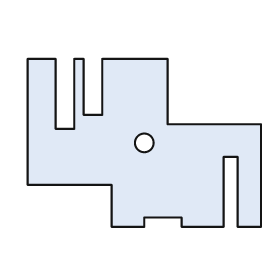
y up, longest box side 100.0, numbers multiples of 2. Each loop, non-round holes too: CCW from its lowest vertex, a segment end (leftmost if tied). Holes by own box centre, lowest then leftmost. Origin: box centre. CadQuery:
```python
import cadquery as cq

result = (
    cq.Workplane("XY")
    .moveTo(-14.0, -36.0)
    .lineTo(0.0, -36.0)
    .lineTo(0.0, -32.0)
    .lineTo(16.0, -32.0)
    .lineTo(16.0, -36.0)
    .lineTo(34.0, -36.0)
    .lineTo(34.0, -6.0)
    .lineTo(40.0, -6.0)
    .lineTo(40.0, -36.0)
    .lineTo(50.0, -36.0)
    .lineTo(50.0, 8.0)
    .lineTo(10.0, 8.0)
    .lineTo(10.0, 36.0)
    .lineTo(-18.0, 36.0)
    .lineTo(-18.0, 12.0)
    .lineTo(-26.0, 12.0)
    .lineTo(-26.0, 36.0)
    .lineTo(-30.0, 36.0)
    .lineTo(-30.0, 6.0)
    .lineTo(-38.0, 6.0)
    .lineTo(-38.0, 36.0)
    .lineTo(-50.0, 36.0)
    .lineTo(-50.0, -18.0)
    .lineTo(-14.0, -18.0)
    .close()
    .moveTo(0.0, 0.0)
    .circle(4.0)
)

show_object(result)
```